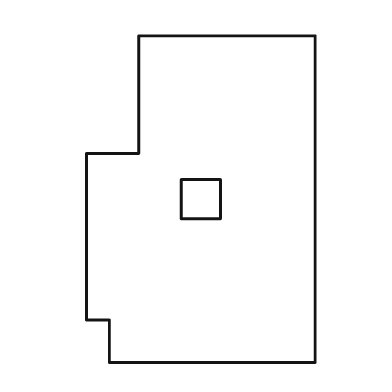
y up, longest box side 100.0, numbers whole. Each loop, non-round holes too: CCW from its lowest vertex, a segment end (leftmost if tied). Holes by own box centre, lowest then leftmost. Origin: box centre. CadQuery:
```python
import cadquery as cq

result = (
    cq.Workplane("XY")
    .moveTo(-28.0, -50.0)
    .lineTo(35.0, -50.0)
    .lineTo(35.0, 50.0)
    .lineTo(-19.0, 50.0)
    .lineTo(-19.0, 14.0)
    .lineTo(-35.0, 14.0)
    .lineTo(-35.0, -37.0)
    .lineTo(-28.0, -37.0)
    .close()
    .moveTo(-6.0, -6.0)
    .lineTo(6.0, -6.0)
    .lineTo(6.0, 6.0)
    .lineTo(-6.0, 6.0)
    .close()
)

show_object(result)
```